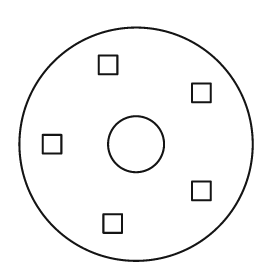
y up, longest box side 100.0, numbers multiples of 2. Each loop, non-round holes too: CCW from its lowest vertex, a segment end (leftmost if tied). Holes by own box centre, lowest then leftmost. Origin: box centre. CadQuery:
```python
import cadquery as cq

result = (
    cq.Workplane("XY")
    .moveTo(0.0, 0.0)
    .circle(50.0)
    .moveTo(-14.0, -38.0)
    .lineTo(-6.0, -38.0)
    .lineTo(-6.0, -30.0)
    .lineTo(-14.0, -30.0)
    .close()
    .moveTo(24.0, -24.0)
    .lineTo(32.0, -24.0)
    .lineTo(32.0, -16.0)
    .lineTo(24.0, -16.0)
    .close()
    .moveTo(-40.0, -4.0)
    .lineTo(-32.0, -4.0)
    .lineTo(-32.0, 4.0)
    .lineTo(-40.0, 4.0)
    .close()
    .moveTo(0.0, 0.0)
    .circle(12.0)
    .moveTo(24.0, 18.0)
    .lineTo(32.0, 18.0)
    .lineTo(32.0, 26.0)
    .lineTo(24.0, 26.0)
    .close()
    .moveTo(-16.0, 30.0)
    .lineTo(-8.0, 30.0)
    .lineTo(-8.0, 38.0)
    .lineTo(-16.0, 38.0)
    .close()
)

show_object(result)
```